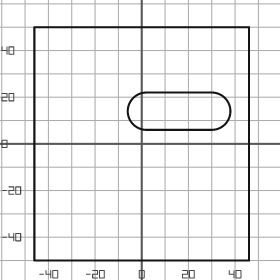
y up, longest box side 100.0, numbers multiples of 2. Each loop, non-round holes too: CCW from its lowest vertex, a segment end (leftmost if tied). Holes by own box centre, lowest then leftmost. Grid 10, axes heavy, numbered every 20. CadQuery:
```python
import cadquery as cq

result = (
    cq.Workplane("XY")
    .moveTo(-46.0, -50.0)
    .lineTo(46.0, -50.0)
    .lineTo(46.0, 50.0)
    .lineTo(-46.0, 50.0)
    .close()
    .moveTo(2.0, 6.0)
    .lineTo(30.0, 6.0)
    .threePointArc((38.0, 14.0), (30.0, 22.0))
    .lineTo(2.0, 22.0)
    .threePointArc((-6.0, 14.0), (2.0, 6.0))
    .close()
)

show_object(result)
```